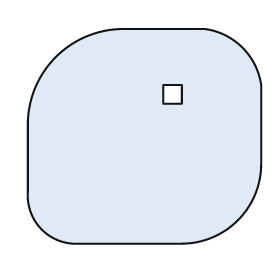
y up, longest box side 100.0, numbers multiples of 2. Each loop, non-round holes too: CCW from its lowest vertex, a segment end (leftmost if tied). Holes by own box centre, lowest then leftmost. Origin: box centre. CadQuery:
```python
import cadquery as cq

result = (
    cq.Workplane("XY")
    .moveTo(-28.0, -46.0)
    .lineTo(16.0, -46.0)
    .threePointArc((40.0, -36.0), (50.0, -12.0))
    .lineTo(50.0, 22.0)
    .threePointArc((42.0, 38.0), (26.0, 46.0))
    .lineTo(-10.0, 46.0)
    .threePointArc((-38.0, 34.0), (-50.0, 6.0))
    .lineTo(-50.0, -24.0)
    .threePointArc((-44.0, -40.0), (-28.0, -46.0))
    .close()
    .moveTo(8.0, 14.0)
    .lineTo(16.0, 14.0)
    .lineTo(16.0, 22.0)
    .lineTo(8.0, 22.0)
    .close()
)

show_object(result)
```